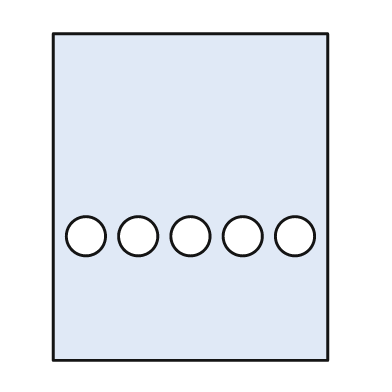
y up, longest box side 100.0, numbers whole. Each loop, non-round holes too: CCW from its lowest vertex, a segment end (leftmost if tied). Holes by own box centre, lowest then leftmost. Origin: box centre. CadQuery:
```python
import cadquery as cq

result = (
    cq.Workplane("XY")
    .moveTo(-42.0, -50.0)
    .lineTo(42.0, -50.0)
    .lineTo(42.0, 50.0)
    .lineTo(-42.0, 50.0)
    .close()
    .moveTo(-32.0, -12.0)
    .circle(6.0)
    .moveTo(-16.0, -12.0)
    .circle(6.0)
    .moveTo(0.0, -12.0)
    .circle(6.0)
    .moveTo(16.0, -12.0)
    .circle(6.0)
    .moveTo(32.0, -12.0)
    .circle(6.0)
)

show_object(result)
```